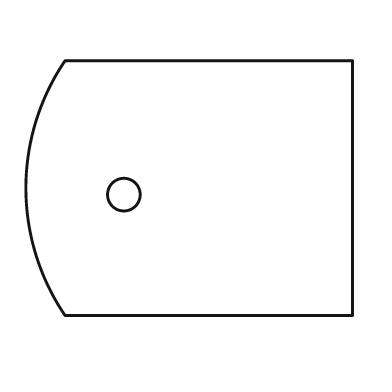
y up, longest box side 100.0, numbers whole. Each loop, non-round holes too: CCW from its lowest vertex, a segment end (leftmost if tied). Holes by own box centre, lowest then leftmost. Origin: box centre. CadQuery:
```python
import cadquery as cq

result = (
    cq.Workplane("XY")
    .moveTo(-38.0, -39.0)
    .lineTo(50.0, -39.0)
    .lineTo(50.0, 39.0)
    .lineTo(-38.0, 39.0)
    .threePointArc((-50.0, 0.0), (-38.0, -39.0))
    .close()
    .moveTo(-20.0, -2.0)
    .circle(5.0)
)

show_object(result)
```